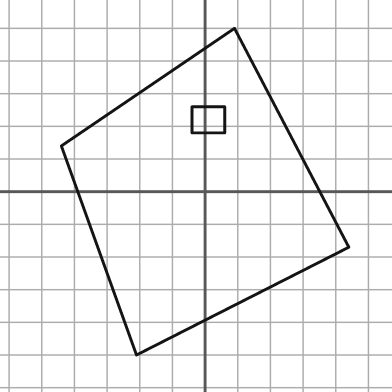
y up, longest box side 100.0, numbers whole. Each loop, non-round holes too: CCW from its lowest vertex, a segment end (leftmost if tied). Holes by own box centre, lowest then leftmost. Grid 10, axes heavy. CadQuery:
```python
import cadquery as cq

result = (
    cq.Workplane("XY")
    .moveTo(-21.0, -50.0)
    .lineTo(44.0, -17.0)
    .lineTo(9.0, 50.0)
    .lineTo(-44.0, 14.0)
    .close()
    .moveTo(-4.0, 18.0)
    .lineTo(6.0, 18.0)
    .lineTo(6.0, 26.0)
    .lineTo(-4.0, 26.0)
    .close()
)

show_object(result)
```